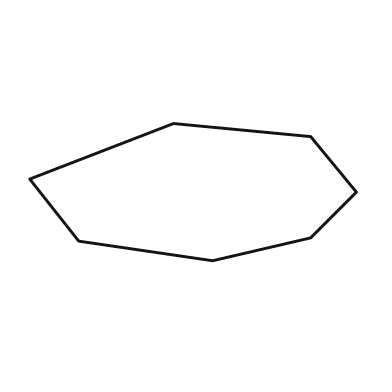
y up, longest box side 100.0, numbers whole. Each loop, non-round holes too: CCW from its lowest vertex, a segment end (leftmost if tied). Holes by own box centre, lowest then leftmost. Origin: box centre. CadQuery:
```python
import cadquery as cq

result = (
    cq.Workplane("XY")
    .moveTo(6.0, -21.0)
    .lineTo(36.0, -14.0)
    .lineTo(50.0, 0.0)
    .lineTo(36.0, 17.0)
    .lineTo(-6.0, 21.0)
    .lineTo(-50.0, 4.0)
    .lineTo(-35.0, -15.0)
    .close()
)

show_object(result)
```